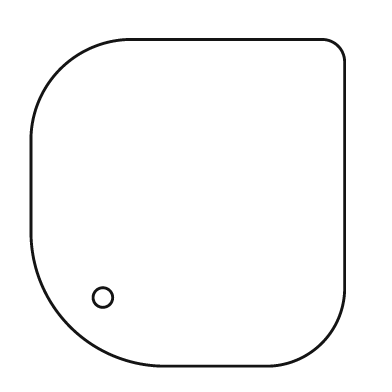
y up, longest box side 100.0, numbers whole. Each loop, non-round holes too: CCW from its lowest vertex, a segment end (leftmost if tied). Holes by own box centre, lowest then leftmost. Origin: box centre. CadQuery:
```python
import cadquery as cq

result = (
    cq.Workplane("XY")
    .moveTo(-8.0, -50.0)
    .lineTo(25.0, -50.0)
    .threePointArc((41.0, -43.0), (48.0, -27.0))
    .lineTo(48.0, 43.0)
    .threePointArc((46.0, 48.0), (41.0, 50.0))
    .lineTo(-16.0, 50.0)
    .threePointArc((-39.0, 41.0), (-48.0, 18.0))
    .lineTo(-48.0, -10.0)
    .threePointArc((-36.0, -38.0), (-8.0, -50.0))
    .close()
    .moveTo(-26.0, -29.0)
    .circle(3.0)
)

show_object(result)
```